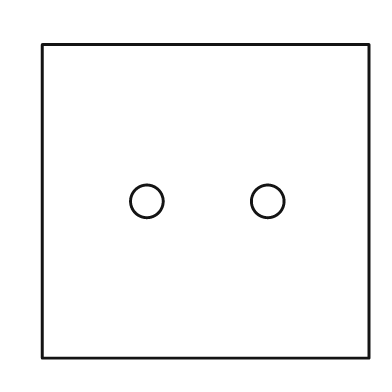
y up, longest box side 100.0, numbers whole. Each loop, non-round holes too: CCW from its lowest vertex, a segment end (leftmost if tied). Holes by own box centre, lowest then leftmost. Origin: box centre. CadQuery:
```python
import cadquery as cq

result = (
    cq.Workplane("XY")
    .moveTo(-50.0, -48.0)
    .lineTo(50.0, -48.0)
    .lineTo(50.0, 48.0)
    .lineTo(-50.0, 48.0)
    .close()
    .moveTo(-18.0, 0.0)
    .circle(5.0)
    .moveTo(19.0, 0.0)
    .circle(5.0)
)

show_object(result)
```